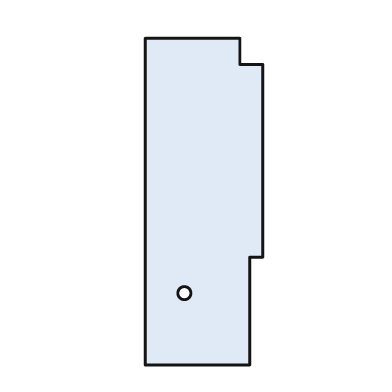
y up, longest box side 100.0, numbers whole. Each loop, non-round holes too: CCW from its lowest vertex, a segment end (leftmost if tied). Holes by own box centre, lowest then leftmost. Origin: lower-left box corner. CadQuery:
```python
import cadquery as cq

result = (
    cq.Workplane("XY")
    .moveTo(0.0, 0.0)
    .lineTo(32.0, 0.0)
    .lineTo(32.0, 33.0)
    .lineTo(36.0, 33.0)
    .lineTo(36.0, 92.0)
    .lineTo(29.0, 92.0)
    .lineTo(29.0, 100.0)
    .lineTo(0.0, 100.0)
    .close()
    .moveTo(12.0, 22.0)
    .circle(2.0)
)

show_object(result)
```